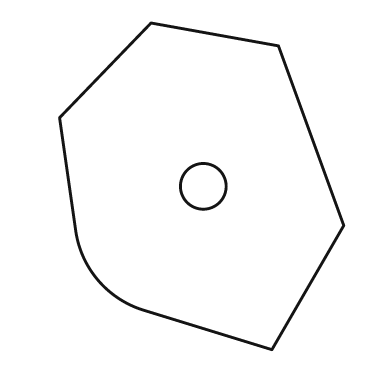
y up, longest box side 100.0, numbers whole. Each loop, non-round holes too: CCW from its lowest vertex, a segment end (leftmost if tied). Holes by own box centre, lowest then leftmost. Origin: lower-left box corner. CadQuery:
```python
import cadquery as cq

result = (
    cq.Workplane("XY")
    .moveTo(65.0, 0.0)
    .lineTo(87.0, 38.0)
    .lineTo(67.0, 93.0)
    .lineTo(28.0, 100.0)
    .lineTo(0.0, 71.0)
    .lineTo(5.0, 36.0)
    .threePointArc((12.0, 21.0), (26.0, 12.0))
    .close()
    .moveTo(44.0, 50.0)
    .circle(7.0)
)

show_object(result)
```